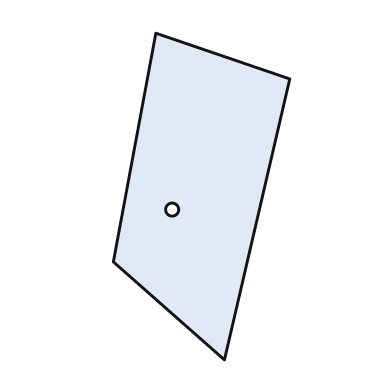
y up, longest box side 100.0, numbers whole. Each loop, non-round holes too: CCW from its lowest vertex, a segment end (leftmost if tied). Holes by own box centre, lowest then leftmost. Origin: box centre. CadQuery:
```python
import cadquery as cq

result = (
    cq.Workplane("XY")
    .moveTo(7.0, -50.0)
    .lineTo(27.0, 36.0)
    .lineTo(-14.0, 50.0)
    .lineTo(-27.0, -20.0)
    .close()
    .moveTo(-9.0, -4.0)
    .circle(2.0)
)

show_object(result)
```